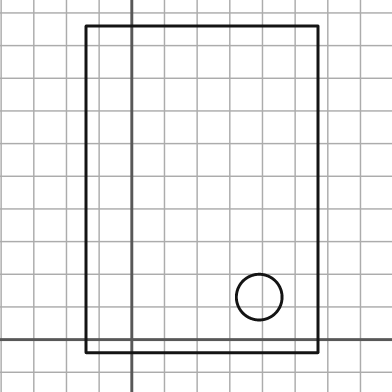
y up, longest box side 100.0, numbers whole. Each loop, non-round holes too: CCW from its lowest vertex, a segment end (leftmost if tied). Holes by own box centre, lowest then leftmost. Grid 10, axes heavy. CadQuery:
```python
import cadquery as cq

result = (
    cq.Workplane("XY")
    .moveTo(-14.0, -4.0)
    .lineTo(57.0, -4.0)
    .lineTo(57.0, 96.0)
    .lineTo(-14.0, 96.0)
    .close()
    .moveTo(39.0, 13.0)
    .circle(7.0)
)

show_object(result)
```